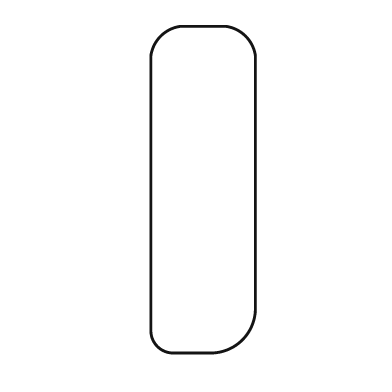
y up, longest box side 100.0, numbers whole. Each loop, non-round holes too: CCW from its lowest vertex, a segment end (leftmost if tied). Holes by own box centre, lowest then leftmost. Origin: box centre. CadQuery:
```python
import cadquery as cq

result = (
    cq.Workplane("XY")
    .moveTo(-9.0, -50.0)
    .lineTo(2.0, -50.0)
    .threePointArc((12.0, -46.0), (16.0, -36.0))
    .lineTo(16.0, 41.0)
    .threePointArc((13.0, 47.0), (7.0, 50.0))
    .lineTo(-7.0, 50.0)
    .threePointArc((-13.0, 47.0), (-16.0, 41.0))
    .lineTo(-16.0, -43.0)
    .threePointArc((-14.0, -48.0), (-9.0, -50.0))
    .close()
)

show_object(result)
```